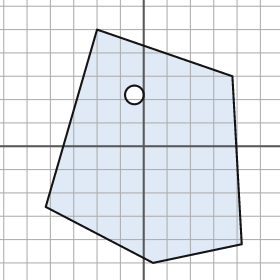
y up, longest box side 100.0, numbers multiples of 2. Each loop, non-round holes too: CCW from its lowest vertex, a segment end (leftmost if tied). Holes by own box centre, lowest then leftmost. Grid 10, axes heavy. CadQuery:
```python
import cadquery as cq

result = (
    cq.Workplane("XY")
    .moveTo(4.0, -50.0)
    .lineTo(42.0, -42.0)
    .lineTo(38.0, 30.0)
    .lineTo(-20.0, 50.0)
    .lineTo(-42.0, -26.0)
    .close()
    .moveTo(-4.0, 22.0)
    .circle(4.0)
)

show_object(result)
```